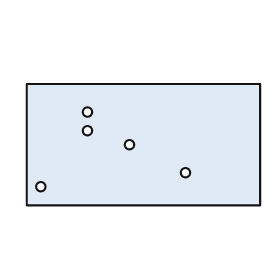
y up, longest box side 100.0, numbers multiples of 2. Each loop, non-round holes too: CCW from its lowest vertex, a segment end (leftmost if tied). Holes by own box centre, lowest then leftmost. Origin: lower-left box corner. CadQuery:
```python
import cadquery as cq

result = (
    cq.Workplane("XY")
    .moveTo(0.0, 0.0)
    .lineTo(100.0, 0.0)
    .lineTo(100.0, 52.0)
    .lineTo(0.0, 52.0)
    .close()
    .moveTo(6.0, 8.0)
    .circle(2.0)
    .moveTo(68.0, 14.0)
    .circle(2.0)
    .moveTo(44.0, 26.0)
    .circle(2.0)
    .moveTo(26.0, 32.0)
    .circle(2.0)
    .moveTo(26.0, 40.0)
    .circle(2.0)
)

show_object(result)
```